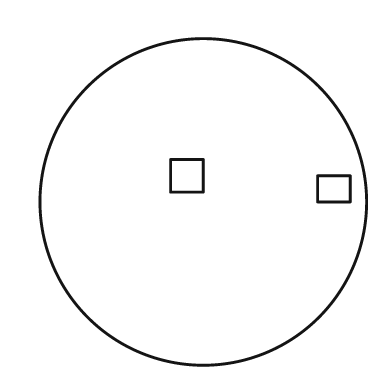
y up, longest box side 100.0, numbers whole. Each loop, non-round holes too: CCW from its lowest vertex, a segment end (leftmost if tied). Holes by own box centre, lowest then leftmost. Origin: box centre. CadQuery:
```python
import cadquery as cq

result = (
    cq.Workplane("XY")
    .moveTo(0.0, 0.0)
    .circle(50.0)
    .moveTo(35.0, 0.0)
    .lineTo(45.0, 0.0)
    .lineTo(45.0, 8.0)
    .lineTo(35.0, 8.0)
    .close()
    .moveTo(-10.0, 3.0)
    .lineTo(0.0, 3.0)
    .lineTo(0.0, 13.0)
    .lineTo(-10.0, 13.0)
    .close()
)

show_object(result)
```